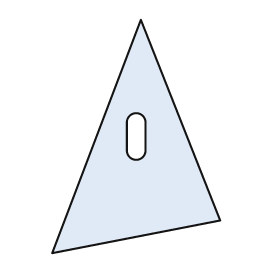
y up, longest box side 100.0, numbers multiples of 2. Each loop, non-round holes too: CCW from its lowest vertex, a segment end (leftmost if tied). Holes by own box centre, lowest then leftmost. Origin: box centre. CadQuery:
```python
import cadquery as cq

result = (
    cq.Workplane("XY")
    .moveTo(-36.0, -50.0)
    .lineTo(36.0, -36.0)
    .lineTo(2.0, 50.0)
    .close()
    .moveTo(-4.0, -6.0)
    .threePointArc((0.0, -10.0), (4.0, -6.0))
    .lineTo(4.0, 6.0)
    .threePointArc((0.0, 10.0), (-4.0, 6.0))
    .close()
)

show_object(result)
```